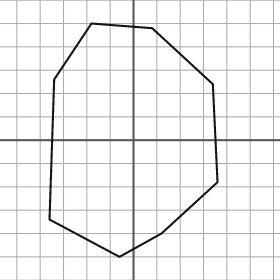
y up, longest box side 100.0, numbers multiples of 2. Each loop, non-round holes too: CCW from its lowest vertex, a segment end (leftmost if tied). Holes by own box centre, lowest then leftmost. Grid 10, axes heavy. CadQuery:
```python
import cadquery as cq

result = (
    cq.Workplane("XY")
    .moveTo(-6.0, -50.0)
    .lineTo(12.0, -40.0)
    .lineTo(36.0, -18.0)
    .lineTo(34.0, 24.0)
    .lineTo(8.0, 48.0)
    .lineTo(-18.0, 50.0)
    .lineTo(-34.0, 26.0)
    .lineTo(-36.0, -34.0)
    .close()
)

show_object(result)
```